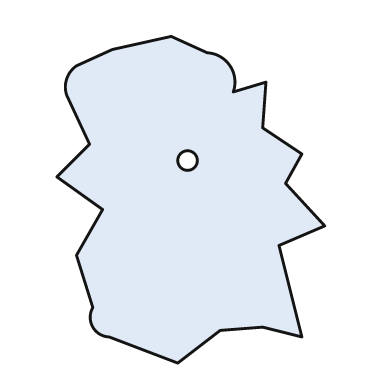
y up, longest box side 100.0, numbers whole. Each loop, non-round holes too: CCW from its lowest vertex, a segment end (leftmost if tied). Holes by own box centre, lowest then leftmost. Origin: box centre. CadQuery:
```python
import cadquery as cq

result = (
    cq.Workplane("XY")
    .moveTo(-4.0, -50.0)
    .lineTo(9.0, -40.0)
    .lineTo(22.0, -39.0)
    .lineTo(34.0, -42.0)
    .lineTo(27.0, -14.0)
    .lineTo(41.0, -8.0)
    .lineTo(29.0, 5.0)
    .lineTo(34.0, 14.0)
    .lineTo(22.0, 22.0)
    .lineTo(23.0, 36.0)
    .lineTo(13.0, 33.0)
    .threePointArc((12.0, 41.0), (5.0, 45.0))
    .lineTo(-6.0, 50.0)
    .lineTo(-24.0, 46.0)
    .lineTo(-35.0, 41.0)
    .threePointArc((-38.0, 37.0), (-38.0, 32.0))
    .lineTo(-31.0, 17.0)
    .lineTo(-41.0, 7.0)
    .lineTo(-27.0, -3.0)
    .lineTo(-35.0, -17.0)
    .lineTo(-30.0, -33.0)
    .threePointArc((-30.0, -39.0), (-25.0, -42.0))
    .close()
    .moveTo(-1.0, 12.0)
    .circle(3.0)
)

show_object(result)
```